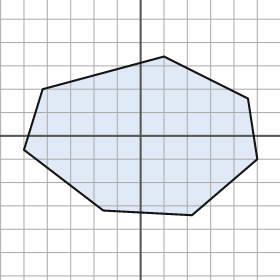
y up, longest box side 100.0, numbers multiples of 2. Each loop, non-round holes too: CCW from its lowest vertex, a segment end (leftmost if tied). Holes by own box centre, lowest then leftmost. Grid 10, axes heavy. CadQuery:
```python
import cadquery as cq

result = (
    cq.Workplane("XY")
    .moveTo(22.0, -34.0)
    .lineTo(50.0, -10.0)
    .lineTo(46.0, 16.0)
    .lineTo(10.0, 34.0)
    .lineTo(-42.0, 20.0)
    .lineTo(-50.0, -6.0)
    .lineTo(-16.0, -32.0)
    .close()
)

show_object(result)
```